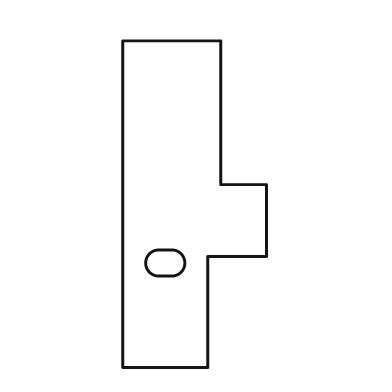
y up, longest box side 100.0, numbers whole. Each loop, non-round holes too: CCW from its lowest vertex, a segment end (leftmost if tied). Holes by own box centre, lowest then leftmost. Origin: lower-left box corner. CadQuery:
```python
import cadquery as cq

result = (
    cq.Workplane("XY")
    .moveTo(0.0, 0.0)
    .lineTo(26.0, 0.0)
    .lineTo(26.0, 34.0)
    .lineTo(44.0, 34.0)
    .lineTo(44.0, 56.0)
    .lineTo(30.0, 56.0)
    .lineTo(30.0, 100.0)
    .lineTo(0.0, 100.0)
    .close()
    .moveTo(11.0, 28.0)
    .lineTo(15.0, 28.0)
    .threePointArc((19.0, 32.0), (15.0, 36.0))
    .lineTo(11.0, 36.0)
    .threePointArc((7.0, 32.0), (11.0, 28.0))
    .close()
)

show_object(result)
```